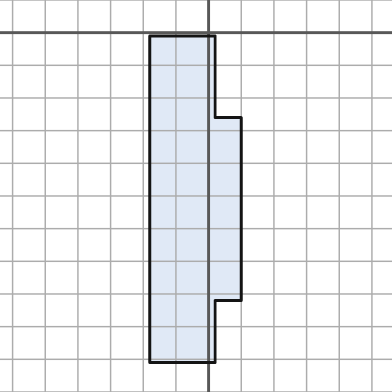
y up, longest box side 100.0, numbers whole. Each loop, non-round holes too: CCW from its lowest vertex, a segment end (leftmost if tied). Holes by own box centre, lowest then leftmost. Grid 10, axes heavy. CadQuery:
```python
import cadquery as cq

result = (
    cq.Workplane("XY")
    .moveTo(-18.0, -101.0)
    .lineTo(2.0, -101.0)
    .lineTo(2.0, -82.0)
    .lineTo(10.0, -82.0)
    .lineTo(10.0, -26.0)
    .lineTo(2.0, -26.0)
    .lineTo(2.0, -1.0)
    .lineTo(-18.0, -1.0)
    .close()
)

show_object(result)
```